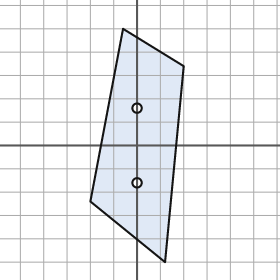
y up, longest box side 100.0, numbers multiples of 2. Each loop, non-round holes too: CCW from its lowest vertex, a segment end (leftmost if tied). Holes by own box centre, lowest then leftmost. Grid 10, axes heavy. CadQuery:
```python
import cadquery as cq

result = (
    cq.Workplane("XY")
    .moveTo(12.0, -50.0)
    .lineTo(20.0, 34.0)
    .lineTo(-6.0, 50.0)
    .lineTo(-20.0, -24.0)
    .close()
    .moveTo(0.0, -16.0)
    .circle(2.0)
    .moveTo(0.0, 16.0)
    .circle(2.0)
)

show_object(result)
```